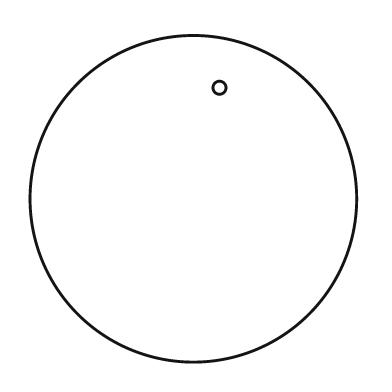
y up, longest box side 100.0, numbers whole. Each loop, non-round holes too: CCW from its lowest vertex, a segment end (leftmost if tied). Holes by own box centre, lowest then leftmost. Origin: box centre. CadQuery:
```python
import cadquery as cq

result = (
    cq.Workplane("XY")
    .moveTo(0.0, 0.0)
    .circle(50.0)
    .moveTo(8.0, 34.0)
    .circle(2.0)
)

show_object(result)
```